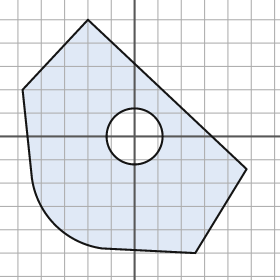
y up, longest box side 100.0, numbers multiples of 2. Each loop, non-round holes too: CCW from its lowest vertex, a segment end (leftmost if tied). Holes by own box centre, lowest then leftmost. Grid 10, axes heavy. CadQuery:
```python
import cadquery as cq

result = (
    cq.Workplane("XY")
    .moveTo(26.0, -50.0)
    .lineTo(48.0, -14.0)
    .lineTo(-20.0, 50.0)
    .lineTo(-48.0, 20.0)
    .lineTo(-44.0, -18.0)
    .threePointArc((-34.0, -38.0), (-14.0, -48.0))
    .close()
    .moveTo(0.0, 0.0)
    .circle(12.0)
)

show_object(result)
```